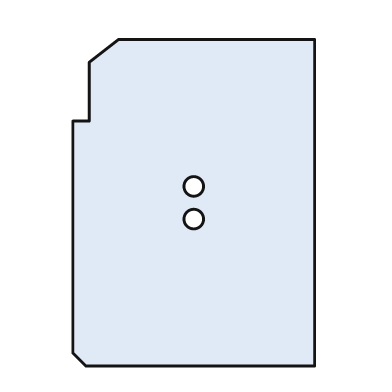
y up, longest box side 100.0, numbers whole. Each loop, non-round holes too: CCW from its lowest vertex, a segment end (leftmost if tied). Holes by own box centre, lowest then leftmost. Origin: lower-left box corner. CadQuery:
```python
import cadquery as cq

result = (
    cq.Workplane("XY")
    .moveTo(4.0, 0.0)
    .lineTo(74.0, 0.0)
    .lineTo(74.0, 100.0)
    .lineTo(14.0, 100.0)
    .lineTo(5.0, 93.0)
    .lineTo(5.0, 75.0)
    .lineTo(0.0, 75.0)
    .lineTo(0.0, 4.0)
    .close()
    .moveTo(37.0, 45.0)
    .circle(3.0)
    .moveTo(37.0, 55.0)
    .circle(3.0)
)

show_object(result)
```